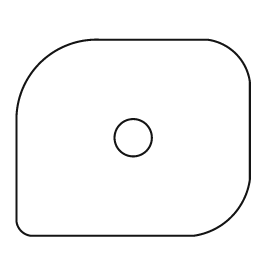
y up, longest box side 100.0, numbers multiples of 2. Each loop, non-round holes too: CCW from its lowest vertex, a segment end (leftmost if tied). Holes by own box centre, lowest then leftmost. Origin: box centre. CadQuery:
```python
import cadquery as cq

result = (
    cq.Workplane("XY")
    .moveTo(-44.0, -42.0)
    .lineTo(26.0, -42.0)
    .threePointArc((42.0, -34.0), (50.0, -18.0))
    .lineTo(50.0, 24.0)
    .threePointArc((44.0, 36.0), (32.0, 42.0))
    .lineTo(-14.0, 42.0)
    .threePointArc((-40.0, 32.0), (-50.0, 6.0))
    .lineTo(-50.0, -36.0)
    .threePointArc((-48.0, -40.0), (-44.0, -42.0))
    .close()
    .moveTo(0.0, 0.0)
    .circle(8.0)
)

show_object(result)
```